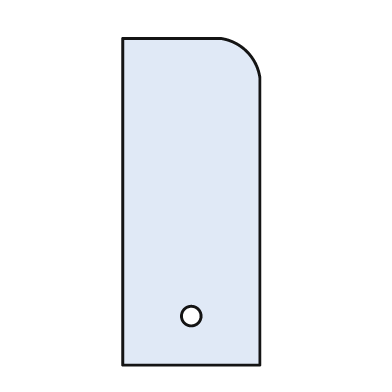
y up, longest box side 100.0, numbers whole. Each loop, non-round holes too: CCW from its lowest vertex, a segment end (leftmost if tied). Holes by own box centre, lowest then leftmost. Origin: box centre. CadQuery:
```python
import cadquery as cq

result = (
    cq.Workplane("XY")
    .moveTo(-21.0, -50.0)
    .lineTo(21.0, -50.0)
    .lineTo(21.0, 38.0)
    .threePointArc((17.0, 46.0), (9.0, 50.0))
    .lineTo(-21.0, 50.0)
    .close()
    .moveTo(0.0, -35.0)
    .circle(3.0)
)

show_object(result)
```